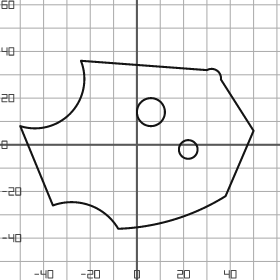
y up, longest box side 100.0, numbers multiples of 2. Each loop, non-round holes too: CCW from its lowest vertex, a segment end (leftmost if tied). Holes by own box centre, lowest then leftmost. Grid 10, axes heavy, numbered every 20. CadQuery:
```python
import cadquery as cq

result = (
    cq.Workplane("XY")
    .moveTo(-8.0, -36.0)
    .threePointArc((16.0, -32.0), (38.0, -22.0))
    .lineTo(50.0, 6.0)
    .lineTo(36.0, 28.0)
    .threePointArc((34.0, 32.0), (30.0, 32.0))
    .lineTo(-24.0, 36.0)
    .threePointArc((-28.0, 14.0), (-50.0, 8.0))
    .lineTo(-36.0, -26.0)
    .threePointArc((-20.0, -26.0), (-8.0, -36.0))
    .close()
    .moveTo(22.0, -2.0)
    .circle(4.0)
    .moveTo(6.0, 14.0)
    .circle(6.0)
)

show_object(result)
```